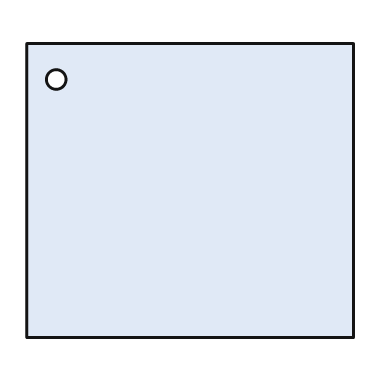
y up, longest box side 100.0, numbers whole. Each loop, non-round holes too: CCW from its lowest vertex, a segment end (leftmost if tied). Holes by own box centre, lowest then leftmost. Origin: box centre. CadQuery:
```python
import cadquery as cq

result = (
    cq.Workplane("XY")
    .moveTo(-50.0, -45.0)
    .lineTo(50.0, -45.0)
    .lineTo(50.0, 45.0)
    .lineTo(-50.0, 45.0)
    .close()
    .moveTo(-41.0, 34.0)
    .circle(3.0)
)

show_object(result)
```